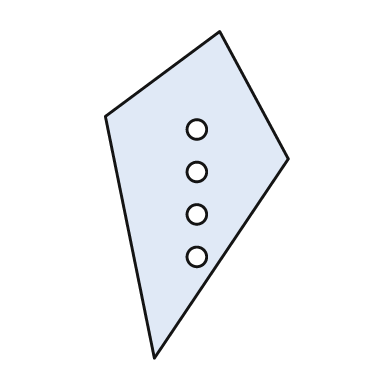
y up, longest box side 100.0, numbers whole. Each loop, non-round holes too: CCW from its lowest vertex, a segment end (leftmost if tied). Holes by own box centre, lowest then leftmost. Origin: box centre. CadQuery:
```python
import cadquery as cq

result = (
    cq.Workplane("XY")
    .moveTo(-13.0, -50.0)
    .lineTo(28.0, 11.0)
    .lineTo(7.0, 50.0)
    .lineTo(-28.0, 24.0)
    .close()
    .moveTo(0.0, -19.0)
    .circle(3.0)
    .moveTo(0.0, -6.0)
    .circle(3.0)
    .moveTo(0.0, 7.0)
    .circle(3.0)
    .moveTo(0.0, 20.0)
    .circle(3.0)
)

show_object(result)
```